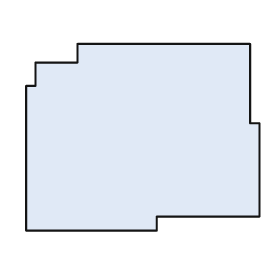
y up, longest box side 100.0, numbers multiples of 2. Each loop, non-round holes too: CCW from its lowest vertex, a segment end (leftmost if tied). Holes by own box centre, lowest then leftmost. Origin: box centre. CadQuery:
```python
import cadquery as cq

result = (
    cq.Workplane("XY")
    .moveTo(-50.0, -40.0)
    .lineTo(6.0, -40.0)
    .lineTo(6.0, -34.0)
    .lineTo(50.0, -34.0)
    .lineTo(50.0, 6.0)
    .lineTo(46.0, 6.0)
    .lineTo(46.0, 40.0)
    .lineTo(-28.0, 40.0)
    .lineTo(-28.0, 32.0)
    .lineTo(-46.0, 32.0)
    .lineTo(-46.0, 22.0)
    .lineTo(-50.0, 22.0)
    .close()
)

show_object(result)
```